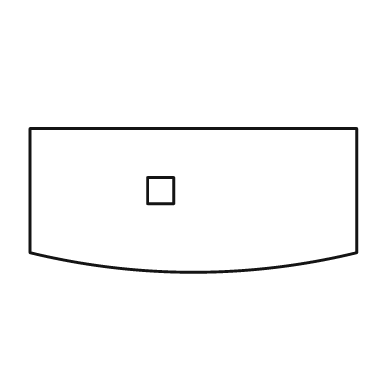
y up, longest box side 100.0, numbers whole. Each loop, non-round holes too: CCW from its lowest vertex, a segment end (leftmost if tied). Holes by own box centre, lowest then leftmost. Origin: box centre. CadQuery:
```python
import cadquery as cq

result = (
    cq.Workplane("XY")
    .moveTo(-50.0, -16.0)
    .threePointArc((0.0, -22.0), (50.0, -16.0))
    .lineTo(50.0, 22.0)
    .lineTo(-50.0, 22.0)
    .close()
    .moveTo(-14.0, -1.0)
    .lineTo(-6.0, -1.0)
    .lineTo(-6.0, 7.0)
    .lineTo(-14.0, 7.0)
    .close()
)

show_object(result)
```